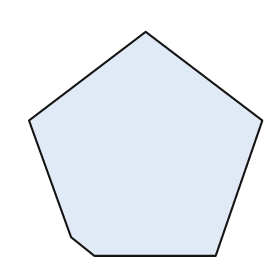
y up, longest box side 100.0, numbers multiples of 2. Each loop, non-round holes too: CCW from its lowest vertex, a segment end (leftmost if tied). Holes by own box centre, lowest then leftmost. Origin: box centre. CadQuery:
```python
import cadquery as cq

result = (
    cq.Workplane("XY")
    .moveTo(-22.0, -48.0)
    .lineTo(30.0, -48.0)
    .lineTo(50.0, 10.0)
    .lineTo(0.0, 48.0)
    .lineTo(-50.0, 10.0)
    .lineTo(-32.0, -40.0)
    .close()
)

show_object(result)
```